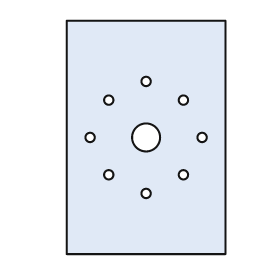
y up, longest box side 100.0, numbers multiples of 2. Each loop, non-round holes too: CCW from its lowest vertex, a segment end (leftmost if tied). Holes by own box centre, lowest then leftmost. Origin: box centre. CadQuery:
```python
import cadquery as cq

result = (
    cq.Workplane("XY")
    .moveTo(-34.0, -50.0)
    .lineTo(34.0, -50.0)
    .lineTo(34.0, 50.0)
    .lineTo(-34.0, 50.0)
    .close()
    .moveTo(0.0, -24.0)
    .circle(2.0)
    .moveTo(-16.0, -16.0)
    .circle(2.0)
    .moveTo(16.0, -16.0)
    .circle(2.0)
    .moveTo(-24.0, 0.0)
    .circle(2.0)
    .moveTo(0.0, 0.0)
    .circle(6.0)
    .moveTo(24.0, 0.0)
    .circle(2.0)
    .moveTo(-16.0, 16.0)
    .circle(2.0)
    .moveTo(16.0, 16.0)
    .circle(2.0)
    .moveTo(0.0, 24.0)
    .circle(2.0)
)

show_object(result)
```